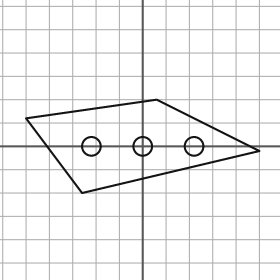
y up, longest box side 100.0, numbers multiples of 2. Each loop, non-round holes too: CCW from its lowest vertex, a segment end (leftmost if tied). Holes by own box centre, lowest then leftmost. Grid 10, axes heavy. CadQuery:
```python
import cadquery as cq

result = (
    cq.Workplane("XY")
    .moveTo(-26.0, -20.0)
    .lineTo(50.0, -2.0)
    .lineTo(6.0, 20.0)
    .lineTo(-50.0, 12.0)
    .close()
    .moveTo(-22.0, 0.0)
    .circle(4.0)
    .moveTo(0.0, 0.0)
    .circle(4.0)
    .moveTo(22.0, 0.0)
    .circle(4.0)
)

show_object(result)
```